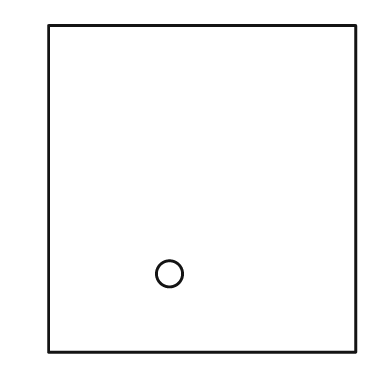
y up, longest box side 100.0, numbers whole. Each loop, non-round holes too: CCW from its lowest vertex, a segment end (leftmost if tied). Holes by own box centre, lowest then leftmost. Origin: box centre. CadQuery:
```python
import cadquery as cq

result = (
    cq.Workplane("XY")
    .moveTo(-47.0, -50.0)
    .lineTo(47.0, -50.0)
    .lineTo(47.0, 50.0)
    .lineTo(-47.0, 50.0)
    .close()
    .moveTo(-10.0, -26.0)
    .circle(4.0)
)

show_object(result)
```